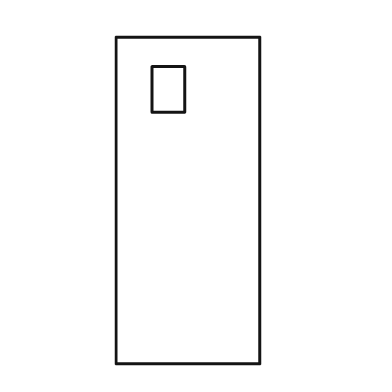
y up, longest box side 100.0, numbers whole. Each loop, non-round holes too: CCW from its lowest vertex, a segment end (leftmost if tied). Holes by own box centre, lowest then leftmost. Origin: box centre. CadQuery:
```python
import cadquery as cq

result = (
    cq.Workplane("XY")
    .moveTo(-22.0, -50.0)
    .lineTo(22.0, -50.0)
    .lineTo(22.0, 50.0)
    .lineTo(-22.0, 50.0)
    .close()
    .moveTo(-11.0, 27.0)
    .lineTo(-1.0, 27.0)
    .lineTo(-1.0, 41.0)
    .lineTo(-11.0, 41.0)
    .close()
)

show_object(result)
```